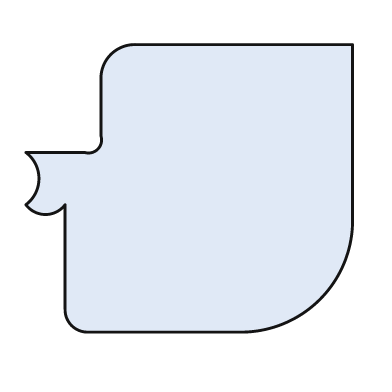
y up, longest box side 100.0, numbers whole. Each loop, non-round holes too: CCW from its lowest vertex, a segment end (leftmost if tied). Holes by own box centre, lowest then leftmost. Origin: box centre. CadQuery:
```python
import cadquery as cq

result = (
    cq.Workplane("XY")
    .moveTo(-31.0, -44.0)
    .lineTo(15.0, -44.0)
    .threePointArc((40.0, -34.0), (50.0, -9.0))
    .lineTo(50.0, 44.0)
    .lineTo(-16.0, 44.0)
    .threePointArc((-24.0, 41.0), (-27.0, 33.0))
    .lineTo(-27.0, 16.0)
    .threePointArc((-28.0, 12.0), (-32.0, 11.0))
    .lineTo(-50.0, 11.0)
    .threePointArc((-46.0, 3.0), (-50.0, -5.0))
    .threePointArc((-44.0, -8.0), (-38.0, -5.0))
    .lineTo(-38.0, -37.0)
    .threePointArc((-36.0, -42.0), (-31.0, -44.0))
    .close()
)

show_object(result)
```